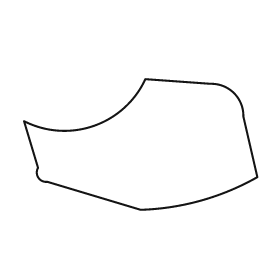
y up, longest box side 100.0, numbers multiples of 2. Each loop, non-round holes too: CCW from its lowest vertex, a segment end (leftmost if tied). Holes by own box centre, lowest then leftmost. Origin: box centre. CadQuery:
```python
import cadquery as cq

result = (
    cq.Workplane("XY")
    .moveTo(0.0, -28.0)
    .threePointArc((26.0, -24.0), (50.0, -14.0))
    .lineTo(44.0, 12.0)
    .threePointArc((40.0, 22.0), (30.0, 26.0))
    .lineTo(2.0, 28.0)
    .threePointArc((-20.0, 8.0), (-50.0, 10.0))
    .lineTo(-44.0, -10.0)
    .threePointArc((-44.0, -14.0), (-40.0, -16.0))
    .close()
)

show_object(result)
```